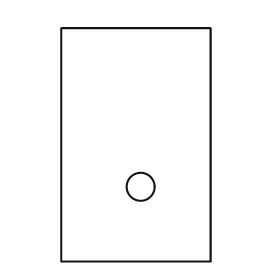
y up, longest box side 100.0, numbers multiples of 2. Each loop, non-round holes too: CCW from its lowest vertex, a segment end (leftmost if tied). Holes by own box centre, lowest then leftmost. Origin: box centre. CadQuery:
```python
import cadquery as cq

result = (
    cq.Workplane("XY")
    .moveTo(-32.0, -50.0)
    .lineTo(32.0, -50.0)
    .lineTo(32.0, 50.0)
    .lineTo(-32.0, 50.0)
    .close()
    .moveTo(2.0, -18.0)
    .circle(6.0)
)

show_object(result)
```